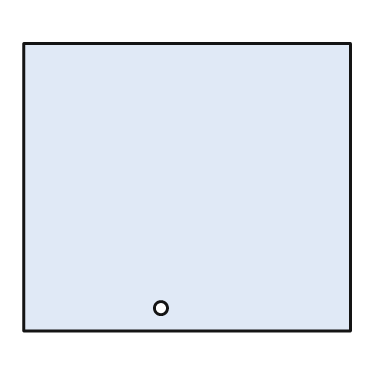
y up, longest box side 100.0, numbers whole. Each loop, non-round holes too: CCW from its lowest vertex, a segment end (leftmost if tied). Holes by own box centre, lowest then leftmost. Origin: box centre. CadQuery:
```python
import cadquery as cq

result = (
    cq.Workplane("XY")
    .moveTo(-50.0, -44.0)
    .lineTo(50.0, -44.0)
    .lineTo(50.0, 44.0)
    .lineTo(-50.0, 44.0)
    .close()
    .moveTo(-8.0, -37.0)
    .circle(2.0)
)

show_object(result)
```